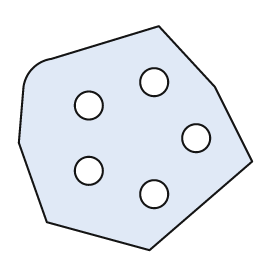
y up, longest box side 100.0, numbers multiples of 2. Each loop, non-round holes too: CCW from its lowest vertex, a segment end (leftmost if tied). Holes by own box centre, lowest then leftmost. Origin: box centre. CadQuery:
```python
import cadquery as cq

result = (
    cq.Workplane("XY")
    .moveTo(6.0, -48.0)
    .lineTo(50.0, -10.0)
    .lineTo(34.0, 22.0)
    .lineTo(10.0, 48.0)
    .lineTo(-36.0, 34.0)
    .threePointArc((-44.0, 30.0), (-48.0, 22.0))
    .lineTo(-50.0, -2.0)
    .lineTo(-38.0, -36.0)
    .close()
    .moveTo(8.0, -24.0)
    .circle(6.0)
    .moveTo(-20.0, -14.0)
    .circle(6.0)
    .moveTo(26.0, 0.0)
    .circle(6.0)
    .moveTo(-20.0, 14.0)
    .circle(6.0)
    .moveTo(8.0, 24.0)
    .circle(6.0)
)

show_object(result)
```